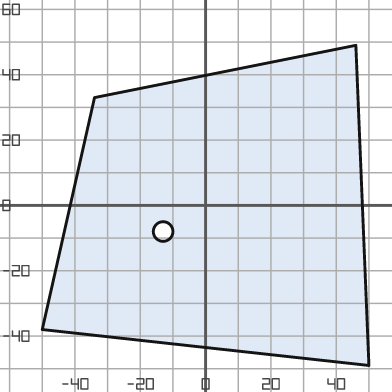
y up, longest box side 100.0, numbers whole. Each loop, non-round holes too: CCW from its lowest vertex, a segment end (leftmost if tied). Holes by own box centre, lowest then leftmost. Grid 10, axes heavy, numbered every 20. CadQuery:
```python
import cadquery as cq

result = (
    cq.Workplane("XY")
    .moveTo(50.0, -49.0)
    .lineTo(46.0, 49.0)
    .lineTo(-34.0, 33.0)
    .lineTo(-50.0, -38.0)
    .close()
    .moveTo(-13.0, -8.0)
    .circle(3.0)
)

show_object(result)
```